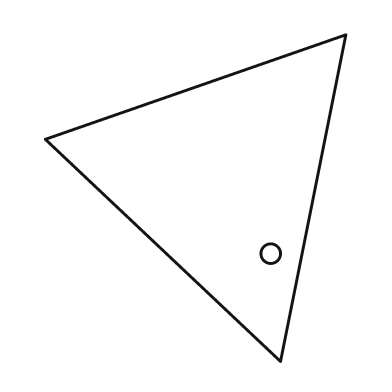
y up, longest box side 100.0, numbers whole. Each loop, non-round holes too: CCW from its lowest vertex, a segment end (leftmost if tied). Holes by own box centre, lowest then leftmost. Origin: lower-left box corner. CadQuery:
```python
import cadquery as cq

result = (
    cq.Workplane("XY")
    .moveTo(72.0, 0.0)
    .lineTo(92.0, 100.0)
    .lineTo(0.0, 68.0)
    .close()
    .moveTo(69.0, 33.0)
    .circle(3.0)
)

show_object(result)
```